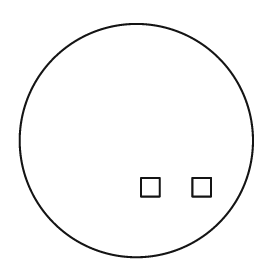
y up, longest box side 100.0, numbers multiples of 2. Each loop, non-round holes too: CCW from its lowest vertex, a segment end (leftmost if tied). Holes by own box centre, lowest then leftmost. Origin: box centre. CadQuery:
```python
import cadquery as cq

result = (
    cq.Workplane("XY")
    .moveTo(0.0, 0.0)
    .circle(50.0)
    .moveTo(2.0, -24.0)
    .lineTo(10.0, -24.0)
    .lineTo(10.0, -16.0)
    .lineTo(2.0, -16.0)
    .close()
    .moveTo(24.0, -24.0)
    .lineTo(32.0, -24.0)
    .lineTo(32.0, -16.0)
    .lineTo(24.0, -16.0)
    .close()
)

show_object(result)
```